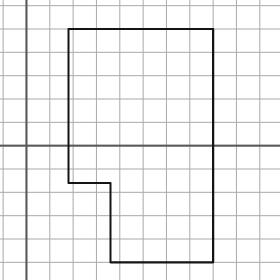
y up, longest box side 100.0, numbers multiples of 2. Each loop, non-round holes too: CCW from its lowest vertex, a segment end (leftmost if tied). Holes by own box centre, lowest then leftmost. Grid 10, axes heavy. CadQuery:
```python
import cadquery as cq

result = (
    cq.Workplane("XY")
    .moveTo(36.0, -50.0)
    .lineTo(80.0, -50.0)
    .lineTo(80.0, 50.0)
    .lineTo(18.0, 50.0)
    .lineTo(18.0, -16.0)
    .lineTo(36.0, -16.0)
    .close()
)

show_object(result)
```